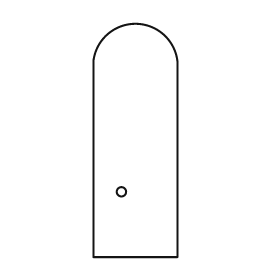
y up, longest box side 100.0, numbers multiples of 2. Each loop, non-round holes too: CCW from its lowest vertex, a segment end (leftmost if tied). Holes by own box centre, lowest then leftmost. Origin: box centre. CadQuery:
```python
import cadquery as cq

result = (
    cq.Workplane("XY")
    .moveTo(-18.0, -50.0)
    .lineTo(18.0, -50.0)
    .lineTo(18.0, 34.0)
    .threePointArc((0.0, 50.0), (-18.0, 34.0))
    .close()
    .moveTo(-6.0, -22.0)
    .circle(2.0)
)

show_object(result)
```